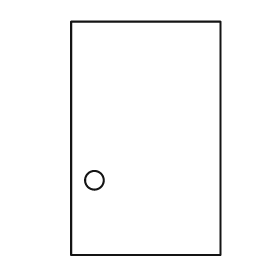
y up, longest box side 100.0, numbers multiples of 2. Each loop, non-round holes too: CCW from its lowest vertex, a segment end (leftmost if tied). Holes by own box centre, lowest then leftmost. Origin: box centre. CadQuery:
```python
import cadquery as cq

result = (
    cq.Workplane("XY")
    .moveTo(-32.0, -50.0)
    .lineTo(32.0, -50.0)
    .lineTo(32.0, 50.0)
    .lineTo(-32.0, 50.0)
    .close()
    .moveTo(-22.0, -18.0)
    .circle(4.0)
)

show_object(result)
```